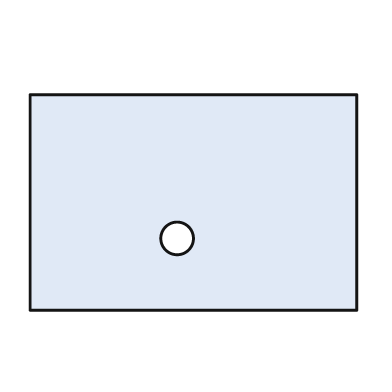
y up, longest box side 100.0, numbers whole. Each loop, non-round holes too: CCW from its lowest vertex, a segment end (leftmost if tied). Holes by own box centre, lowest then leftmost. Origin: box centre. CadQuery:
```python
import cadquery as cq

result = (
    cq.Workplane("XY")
    .moveTo(-50.0, -33.0)
    .lineTo(50.0, -33.0)
    .lineTo(50.0, 33.0)
    .lineTo(-50.0, 33.0)
    .close()
    .moveTo(-5.0, -11.0)
    .circle(5.0)
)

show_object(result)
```